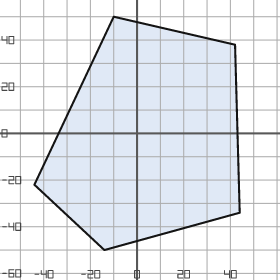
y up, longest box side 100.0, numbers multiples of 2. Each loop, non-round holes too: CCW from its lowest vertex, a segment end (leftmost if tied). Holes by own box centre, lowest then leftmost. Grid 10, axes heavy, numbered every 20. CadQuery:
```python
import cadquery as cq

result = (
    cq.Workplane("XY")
    .moveTo(-14.0, -50.0)
    .lineTo(44.0, -34.0)
    .lineTo(42.0, 38.0)
    .lineTo(-10.0, 50.0)
    .lineTo(-44.0, -22.0)
    .close()
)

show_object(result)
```